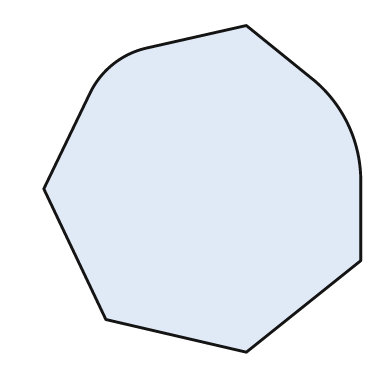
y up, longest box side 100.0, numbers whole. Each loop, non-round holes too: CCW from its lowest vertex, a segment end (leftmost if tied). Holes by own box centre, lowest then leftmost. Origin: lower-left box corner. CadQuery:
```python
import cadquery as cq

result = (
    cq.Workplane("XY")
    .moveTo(62.0, 0.0)
    .lineTo(97.0, 28.0)
    .lineTo(97.0, 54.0)
    .threePointArc((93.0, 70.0), (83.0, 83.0))
    .lineTo(62.0, 100.0)
    .lineTo(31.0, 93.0)
    .threePointArc((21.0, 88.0), (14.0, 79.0))
    .lineTo(0.0, 50.0)
    .lineTo(19.0, 10.0)
    .close()
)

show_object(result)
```